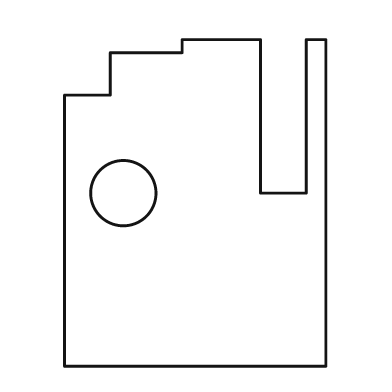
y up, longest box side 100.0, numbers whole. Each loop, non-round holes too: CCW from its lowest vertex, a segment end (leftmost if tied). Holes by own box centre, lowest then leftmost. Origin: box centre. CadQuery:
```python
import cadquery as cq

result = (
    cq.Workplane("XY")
    .moveTo(-40.0, -50.0)
    .lineTo(40.0, -50.0)
    .lineTo(40.0, 50.0)
    .lineTo(34.0, 50.0)
    .lineTo(34.0, 3.0)
    .lineTo(20.0, 3.0)
    .lineTo(20.0, 50.0)
    .lineTo(-4.0, 50.0)
    .lineTo(-4.0, 46.0)
    .lineTo(-26.0, 46.0)
    .lineTo(-26.0, 33.0)
    .lineTo(-40.0, 33.0)
    .close()
    .moveTo(-22.0, 3.0)
    .circle(10.0)
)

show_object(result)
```